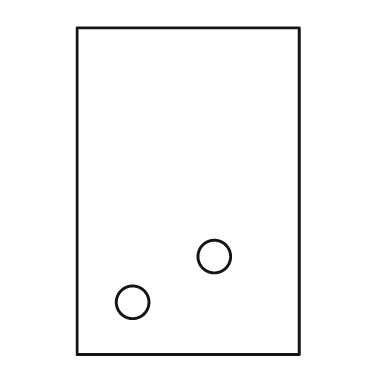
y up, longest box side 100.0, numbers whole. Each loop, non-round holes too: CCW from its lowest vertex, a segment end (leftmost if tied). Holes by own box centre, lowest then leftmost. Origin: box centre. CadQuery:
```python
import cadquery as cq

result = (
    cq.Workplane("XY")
    .moveTo(-34.0, -50.0)
    .lineTo(34.0, -50.0)
    .lineTo(34.0, 50.0)
    .lineTo(-34.0, 50.0)
    .close()
    .moveTo(-17.0, -34.0)
    .circle(5.0)
    .moveTo(8.0, -20.0)
    .circle(5.0)
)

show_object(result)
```